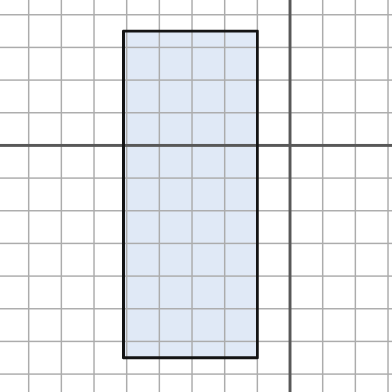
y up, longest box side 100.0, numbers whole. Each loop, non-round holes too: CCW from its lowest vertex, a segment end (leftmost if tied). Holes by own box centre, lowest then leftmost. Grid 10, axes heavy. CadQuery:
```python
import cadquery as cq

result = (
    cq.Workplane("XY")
    .moveTo(-51.0, -65.0)
    .lineTo(-10.0, -65.0)
    .lineTo(-10.0, 35.0)
    .lineTo(-51.0, 35.0)
    .close()
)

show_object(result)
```